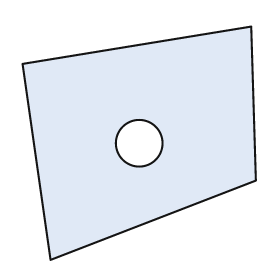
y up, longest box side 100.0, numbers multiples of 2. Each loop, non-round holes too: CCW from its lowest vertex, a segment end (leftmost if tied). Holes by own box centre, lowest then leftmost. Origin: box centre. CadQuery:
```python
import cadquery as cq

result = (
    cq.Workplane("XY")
    .moveTo(-38.0, -50.0)
    .lineTo(50.0, -16.0)
    .lineTo(48.0, 50.0)
    .lineTo(-50.0, 34.0)
    .close()
    .moveTo(0.0, 0.0)
    .circle(10.0)
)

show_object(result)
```